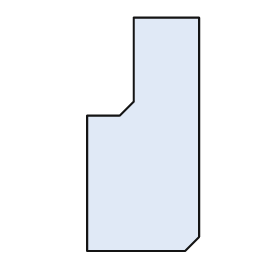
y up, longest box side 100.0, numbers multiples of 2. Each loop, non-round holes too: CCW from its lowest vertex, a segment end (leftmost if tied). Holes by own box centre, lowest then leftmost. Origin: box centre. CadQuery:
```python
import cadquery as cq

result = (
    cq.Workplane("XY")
    .moveTo(-24.0, -50.0)
    .lineTo(18.0, -50.0)
    .lineTo(24.0, -44.0)
    .lineTo(24.0, 50.0)
    .lineTo(-4.0, 50.0)
    .lineTo(-4.0, 14.0)
    .lineTo(-10.0, 8.0)
    .lineTo(-24.0, 8.0)
    .close()
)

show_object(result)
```